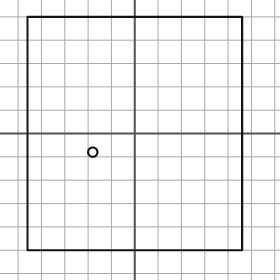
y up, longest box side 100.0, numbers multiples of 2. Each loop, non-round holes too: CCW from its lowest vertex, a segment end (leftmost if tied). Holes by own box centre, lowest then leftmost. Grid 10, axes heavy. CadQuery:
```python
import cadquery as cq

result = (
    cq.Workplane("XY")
    .moveTo(-46.0, -50.0)
    .lineTo(46.0, -50.0)
    .lineTo(46.0, 50.0)
    .lineTo(-46.0, 50.0)
    .close()
    .moveTo(-18.0, -8.0)
    .circle(2.0)
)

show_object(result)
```